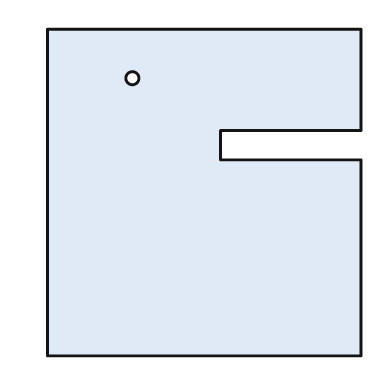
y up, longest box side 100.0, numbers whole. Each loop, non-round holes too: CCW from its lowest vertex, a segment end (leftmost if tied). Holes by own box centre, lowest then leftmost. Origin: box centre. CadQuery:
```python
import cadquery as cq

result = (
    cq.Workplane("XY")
    .moveTo(-48.0, -50.0)
    .lineTo(48.0, -50.0)
    .lineTo(48.0, 10.0)
    .lineTo(5.0, 10.0)
    .lineTo(5.0, 19.0)
    .lineTo(48.0, 19.0)
    .lineTo(48.0, 50.0)
    .lineTo(-48.0, 50.0)
    .close()
    .moveTo(-22.0, 35.0)
    .circle(2.0)
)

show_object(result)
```